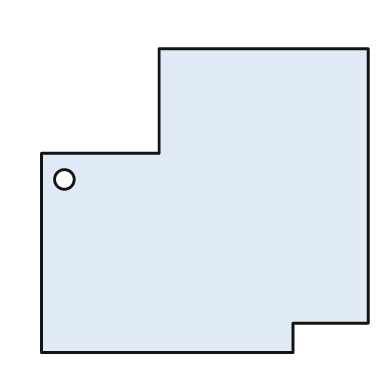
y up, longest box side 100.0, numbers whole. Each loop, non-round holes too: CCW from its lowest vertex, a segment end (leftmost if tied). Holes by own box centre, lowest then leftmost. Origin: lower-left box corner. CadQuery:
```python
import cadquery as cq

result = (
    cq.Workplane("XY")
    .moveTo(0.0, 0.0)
    .lineTo(77.0, 0.0)
    .lineTo(77.0, 9.0)
    .lineTo(100.0, 9.0)
    .lineTo(100.0, 93.0)
    .lineTo(36.0, 93.0)
    .lineTo(36.0, 61.0)
    .lineTo(0.0, 61.0)
    .close()
    .moveTo(7.0, 53.0)
    .circle(3.0)
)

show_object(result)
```